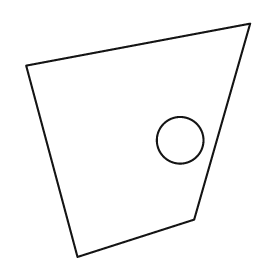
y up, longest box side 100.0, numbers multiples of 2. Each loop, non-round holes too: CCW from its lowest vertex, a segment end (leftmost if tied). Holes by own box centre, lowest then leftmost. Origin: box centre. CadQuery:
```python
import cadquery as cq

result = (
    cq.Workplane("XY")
    .moveTo(-26.0, -50.0)
    .lineTo(24.0, -34.0)
    .lineTo(48.0, 50.0)
    .lineTo(-48.0, 32.0)
    .close()
    .moveTo(18.0, 0.0)
    .circle(10.0)
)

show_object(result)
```